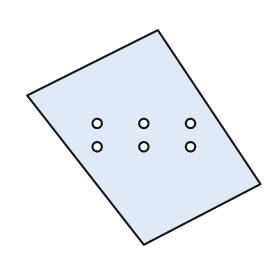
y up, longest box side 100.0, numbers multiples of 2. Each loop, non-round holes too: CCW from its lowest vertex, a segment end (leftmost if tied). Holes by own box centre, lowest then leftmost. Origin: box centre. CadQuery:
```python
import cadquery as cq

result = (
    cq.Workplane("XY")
    .moveTo(0.0, -46.0)
    .lineTo(50.0, -20.0)
    .lineTo(6.0, 46.0)
    .lineTo(-50.0, 18.0)
    .close()
    .moveTo(-20.0, -4.0)
    .circle(2.0)
    .moveTo(0.0, -4.0)
    .circle(2.0)
    .moveTo(20.0, -4.0)
    .circle(2.0)
    .moveTo(-20.0, 6.0)
    .circle(2.0)
    .moveTo(0.0, 6.0)
    .circle(2.0)
    .moveTo(20.0, 6.0)
    .circle(2.0)
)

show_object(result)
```